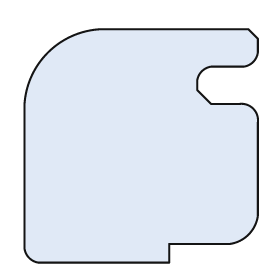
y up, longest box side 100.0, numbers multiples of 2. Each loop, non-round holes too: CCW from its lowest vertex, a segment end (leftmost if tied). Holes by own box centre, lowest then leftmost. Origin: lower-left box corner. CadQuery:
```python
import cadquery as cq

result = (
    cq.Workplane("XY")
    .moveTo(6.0, 0.0)
    .lineTo(62.0, 0.0)
    .lineTo(62.0, 8.0)
    .lineTo(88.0, 8.0)
    .threePointArc((96.0, 12.0), (100.0, 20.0))
    .lineTo(100.0, 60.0)
    .threePointArc((98.0, 66.0), (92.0, 68.0))
    .lineTo(80.0, 68.0)
    .lineTo(74.0, 74.0)
    .lineTo(74.0, 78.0)
    .threePointArc((76.0, 82.0), (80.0, 84.0))
    .lineTo(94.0, 84.0)
    .threePointArc((98.0, 86.0), (100.0, 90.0))
    .lineTo(100.0, 96.0)
    .lineTo(96.0, 100.0)
    .lineTo(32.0, 100.0)
    .threePointArc((10.0, 90.0), (0.0, 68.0))
    .lineTo(0.0, 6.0)
    .threePointArc((2.0, 2.0), (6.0, 0.0))
    .close()
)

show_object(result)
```